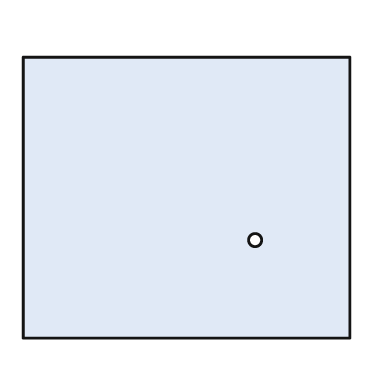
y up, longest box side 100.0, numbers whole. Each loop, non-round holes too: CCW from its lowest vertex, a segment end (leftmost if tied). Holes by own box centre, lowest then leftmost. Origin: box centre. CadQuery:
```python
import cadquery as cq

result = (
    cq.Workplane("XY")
    .moveTo(-50.0, -43.0)
    .lineTo(50.0, -43.0)
    .lineTo(50.0, 43.0)
    .lineTo(-50.0, 43.0)
    .close()
    .moveTo(21.0, -13.0)
    .circle(2.0)
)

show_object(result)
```